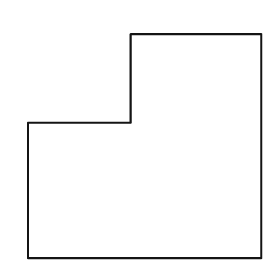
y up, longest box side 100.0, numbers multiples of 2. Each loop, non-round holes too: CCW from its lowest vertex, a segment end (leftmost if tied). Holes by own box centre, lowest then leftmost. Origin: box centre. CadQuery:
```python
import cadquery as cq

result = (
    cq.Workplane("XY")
    .moveTo(-50.0, -48.0)
    .lineTo(50.0, -48.0)
    .lineTo(50.0, 48.0)
    .lineTo(-6.0, 48.0)
    .lineTo(-6.0, 10.0)
    .lineTo(-50.0, 10.0)
    .close()
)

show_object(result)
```